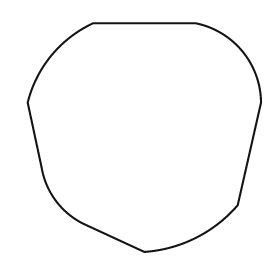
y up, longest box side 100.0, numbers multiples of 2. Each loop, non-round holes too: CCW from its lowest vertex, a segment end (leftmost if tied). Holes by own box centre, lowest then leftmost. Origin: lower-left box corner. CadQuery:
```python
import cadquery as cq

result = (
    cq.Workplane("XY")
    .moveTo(50.0, 0.0)
    .threePointArc((72.0, 6.0), (90.0, 20.0))
    .lineTo(100.0, 64.0)
    .threePointArc((92.0, 86.0), (72.0, 98.0))
    .lineTo(28.0, 98.0)
    .threePointArc((10.0, 84.0), (0.0, 64.0))
    .lineTo(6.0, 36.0)
    .threePointArc((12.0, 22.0), (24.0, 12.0))
    .close()
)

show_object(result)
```